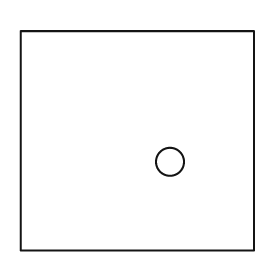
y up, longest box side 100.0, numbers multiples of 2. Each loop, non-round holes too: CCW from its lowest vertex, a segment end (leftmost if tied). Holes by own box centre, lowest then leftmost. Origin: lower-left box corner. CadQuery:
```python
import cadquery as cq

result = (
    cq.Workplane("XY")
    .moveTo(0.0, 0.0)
    .lineTo(100.0, 0.0)
    .lineTo(100.0, 94.0)
    .lineTo(0.0, 94.0)
    .close()
    .moveTo(64.0, 38.0)
    .circle(6.0)
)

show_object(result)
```